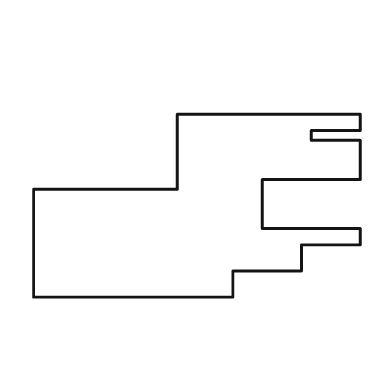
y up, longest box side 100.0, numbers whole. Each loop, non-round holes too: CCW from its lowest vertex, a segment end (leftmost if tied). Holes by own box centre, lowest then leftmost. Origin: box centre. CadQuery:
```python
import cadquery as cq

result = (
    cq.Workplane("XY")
    .moveTo(-50.0, -28.0)
    .lineTo(11.0, -28.0)
    .lineTo(11.0, -20.0)
    .lineTo(32.0, -20.0)
    .lineTo(32.0, -12.0)
    .lineTo(50.0, -12.0)
    .lineTo(50.0, -7.0)
    .lineTo(20.0, -7.0)
    .lineTo(20.0, 8.0)
    .lineTo(50.0, 8.0)
    .lineTo(50.0, 20.0)
    .lineTo(35.0, 20.0)
    .lineTo(35.0, 23.0)
    .lineTo(50.0, 23.0)
    .lineTo(50.0, 28.0)
    .lineTo(-6.0, 28.0)
    .lineTo(-6.0, 5.0)
    .lineTo(-50.0, 5.0)
    .close()
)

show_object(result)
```